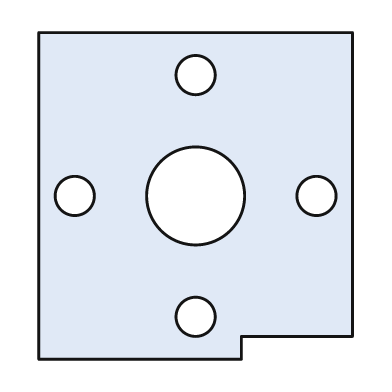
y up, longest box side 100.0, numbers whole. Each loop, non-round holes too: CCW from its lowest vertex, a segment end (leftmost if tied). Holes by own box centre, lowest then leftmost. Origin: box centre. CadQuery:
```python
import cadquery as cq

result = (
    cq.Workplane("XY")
    .moveTo(-48.0, -50.0)
    .lineTo(14.0, -50.0)
    .lineTo(14.0, -43.0)
    .lineTo(48.0, -43.0)
    .lineTo(48.0, 50.0)
    .lineTo(-48.0, 50.0)
    .close()
    .moveTo(0.0, -37.0)
    .circle(6.0)
    .moveTo(-37.0, 0.0)
    .circle(6.0)
    .moveTo(0.0, 0.0)
    .circle(15.0)
    .moveTo(37.0, 0.0)
    .circle(6.0)
    .moveTo(0.0, 37.0)
    .circle(6.0)
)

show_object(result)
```